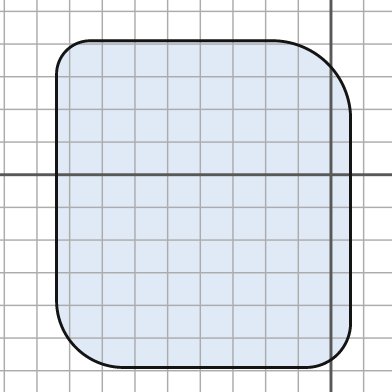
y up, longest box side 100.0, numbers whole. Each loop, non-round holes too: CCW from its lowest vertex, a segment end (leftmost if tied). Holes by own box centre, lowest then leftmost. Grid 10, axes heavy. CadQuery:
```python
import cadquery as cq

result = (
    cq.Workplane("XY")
    .moveTo(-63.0, -59.0)
    .lineTo(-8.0, -59.0)
    .threePointArc((2.0, -55.0), (6.0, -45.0))
    .lineTo(6.0, 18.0)
    .threePointArc((-1.0, 34.0), (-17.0, 41.0))
    .lineTo(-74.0, 41.0)
    .threePointArc((-81.0, 38.0), (-84.0, 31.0))
    .lineTo(-84.0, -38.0)
    .threePointArc((-78.0, -53.0), (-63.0, -59.0))
    .close()
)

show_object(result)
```